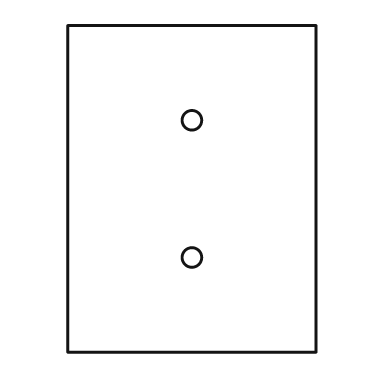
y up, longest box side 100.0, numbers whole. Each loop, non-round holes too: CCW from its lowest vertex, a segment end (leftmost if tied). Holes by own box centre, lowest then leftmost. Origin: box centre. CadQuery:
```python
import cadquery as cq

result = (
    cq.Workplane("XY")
    .moveTo(-38.0, -50.0)
    .lineTo(38.0, -50.0)
    .lineTo(38.0, 50.0)
    .lineTo(-38.0, 50.0)
    .close()
    .moveTo(0.0, -21.0)
    .circle(3.0)
    .moveTo(0.0, 21.0)
    .circle(3.0)
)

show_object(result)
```